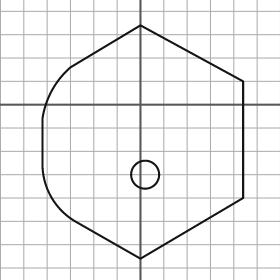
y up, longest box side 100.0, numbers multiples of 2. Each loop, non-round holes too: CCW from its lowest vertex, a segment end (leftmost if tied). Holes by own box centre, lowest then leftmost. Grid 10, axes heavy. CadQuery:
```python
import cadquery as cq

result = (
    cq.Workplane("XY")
    .moveTo(0.0, -66.0)
    .lineTo(44.0, -40.0)
    .lineTo(44.0, 10.0)
    .lineTo(0.0, 34.0)
    .lineTo(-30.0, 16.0)
    .threePointArc((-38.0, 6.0), (-42.0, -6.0))
    .lineTo(-42.0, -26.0)
    .threePointArc((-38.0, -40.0), (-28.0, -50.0))
    .close()
    .moveTo(2.0, -30.0)
    .circle(6.0)
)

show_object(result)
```